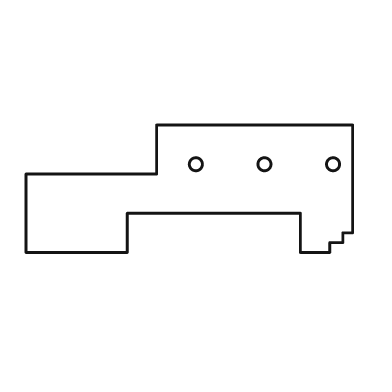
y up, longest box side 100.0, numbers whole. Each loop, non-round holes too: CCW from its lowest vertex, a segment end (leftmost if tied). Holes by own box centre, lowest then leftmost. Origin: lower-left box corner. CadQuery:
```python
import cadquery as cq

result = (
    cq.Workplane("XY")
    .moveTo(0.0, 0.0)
    .lineTo(31.0, 0.0)
    .lineTo(31.0, 12.0)
    .lineTo(84.0, 12.0)
    .lineTo(84.0, 0.0)
    .lineTo(93.0, 0.0)
    .lineTo(93.0, 3.0)
    .lineTo(97.0, 3.0)
    .lineTo(97.0, 6.0)
    .lineTo(100.0, 6.0)
    .lineTo(100.0, 39.0)
    .lineTo(40.0, 39.0)
    .lineTo(40.0, 24.0)
    .lineTo(0.0, 24.0)
    .close()
    .moveTo(52.0, 27.0)
    .circle(2.0)
    .moveTo(73.0, 27.0)
    .circle(2.0)
    .moveTo(94.0, 27.0)
    .circle(2.0)
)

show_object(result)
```